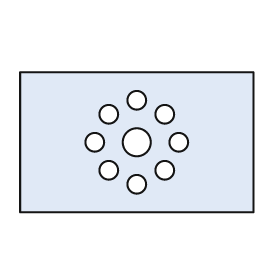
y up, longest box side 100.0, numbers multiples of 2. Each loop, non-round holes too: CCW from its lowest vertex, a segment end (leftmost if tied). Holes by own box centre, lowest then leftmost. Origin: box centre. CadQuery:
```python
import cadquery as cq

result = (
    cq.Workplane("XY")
    .moveTo(-50.0, -30.0)
    .lineTo(50.0, -30.0)
    .lineTo(50.0, 30.0)
    .lineTo(-50.0, 30.0)
    .close()
    .moveTo(0.0, -18.0)
    .circle(4.0)
    .moveTo(-12.0, -12.0)
    .circle(4.0)
    .moveTo(12.0, -12.0)
    .circle(4.0)
    .moveTo(-18.0, 0.0)
    .circle(4.0)
    .moveTo(0.0, 0.0)
    .circle(6.0)
    .moveTo(18.0, 0.0)
    .circle(4.0)
    .moveTo(-12.0, 12.0)
    .circle(4.0)
    .moveTo(12.0, 12.0)
    .circle(4.0)
    .moveTo(0.0, 18.0)
    .circle(4.0)
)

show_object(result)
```